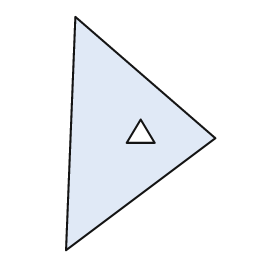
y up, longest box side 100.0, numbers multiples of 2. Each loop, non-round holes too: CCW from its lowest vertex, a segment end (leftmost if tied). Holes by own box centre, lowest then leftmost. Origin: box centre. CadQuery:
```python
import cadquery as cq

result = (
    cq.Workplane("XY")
    .moveTo(-32.0, -50.0)
    .lineTo(32.0, -2.0)
    .lineTo(-28.0, 50.0)
    .close()
    .moveTo(-6.0, -4.0)
    .lineTo(6.0, -4.0)
    .lineTo(0.0, 6.0)
    .close()
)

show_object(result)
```